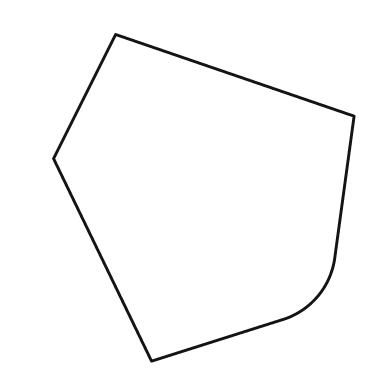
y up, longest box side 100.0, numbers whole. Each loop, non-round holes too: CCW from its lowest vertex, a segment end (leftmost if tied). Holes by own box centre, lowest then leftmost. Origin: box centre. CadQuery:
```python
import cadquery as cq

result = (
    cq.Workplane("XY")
    .moveTo(-16.0, -50.0)
    .lineTo(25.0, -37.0)
    .threePointArc((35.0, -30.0), (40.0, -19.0))
    .lineTo(46.0, 25.0)
    .lineTo(-27.0, 50.0)
    .lineTo(-46.0, 12.0)
    .close()
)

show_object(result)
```